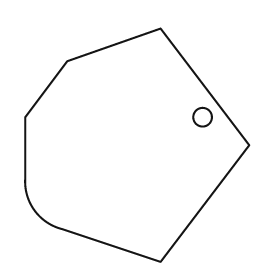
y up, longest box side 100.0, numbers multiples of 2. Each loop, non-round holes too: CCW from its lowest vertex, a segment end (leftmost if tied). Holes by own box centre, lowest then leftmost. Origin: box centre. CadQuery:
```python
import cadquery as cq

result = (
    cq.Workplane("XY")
    .moveTo(10.0, -50.0)
    .lineTo(48.0, 0.0)
    .lineTo(10.0, 50.0)
    .lineTo(-30.0, 36.0)
    .lineTo(-48.0, 12.0)
    .lineTo(-48.0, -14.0)
    .threePointArc((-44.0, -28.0), (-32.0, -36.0))
    .close()
    .moveTo(28.0, 12.0)
    .circle(4.0)
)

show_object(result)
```